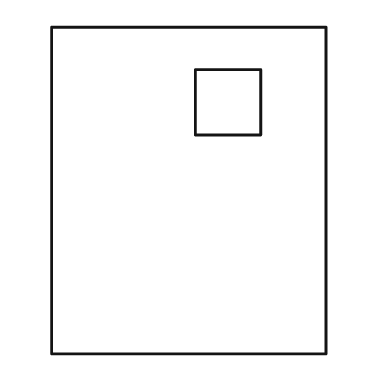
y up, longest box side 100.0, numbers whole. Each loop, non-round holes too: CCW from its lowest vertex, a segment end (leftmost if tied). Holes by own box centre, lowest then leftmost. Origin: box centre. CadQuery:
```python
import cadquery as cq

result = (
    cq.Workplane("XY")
    .moveTo(-42.0, -50.0)
    .lineTo(42.0, -50.0)
    .lineTo(42.0, 50.0)
    .lineTo(-42.0, 50.0)
    .close()
    .moveTo(2.0, 17.0)
    .lineTo(22.0, 17.0)
    .lineTo(22.0, 37.0)
    .lineTo(2.0, 37.0)
    .close()
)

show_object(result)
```